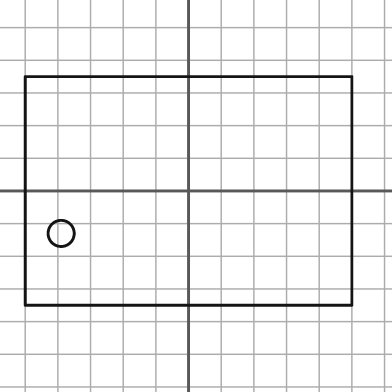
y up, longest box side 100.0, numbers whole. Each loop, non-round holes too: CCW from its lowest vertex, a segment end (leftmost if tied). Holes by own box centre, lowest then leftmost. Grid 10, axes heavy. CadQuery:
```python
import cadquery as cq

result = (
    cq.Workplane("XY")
    .moveTo(-50.0, -35.0)
    .lineTo(50.0, -35.0)
    .lineTo(50.0, 35.0)
    .lineTo(-50.0, 35.0)
    .close()
    .moveTo(-39.0, -13.0)
    .circle(4.0)
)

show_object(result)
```